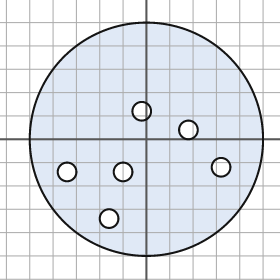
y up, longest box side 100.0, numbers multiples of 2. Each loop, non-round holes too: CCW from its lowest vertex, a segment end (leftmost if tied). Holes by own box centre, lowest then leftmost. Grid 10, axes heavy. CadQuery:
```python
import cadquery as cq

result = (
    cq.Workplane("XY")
    .moveTo(0.0, 0.0)
    .circle(50.0)
    .moveTo(-16.0, -34.0)
    .circle(4.0)
    .moveTo(-34.0, -14.0)
    .circle(4.0)
    .moveTo(-10.0, -14.0)
    .circle(4.0)
    .moveTo(32.0, -12.0)
    .circle(4.0)
    .moveTo(18.0, 4.0)
    .circle(4.0)
    .moveTo(-2.0, 12.0)
    .circle(4.0)
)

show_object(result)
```